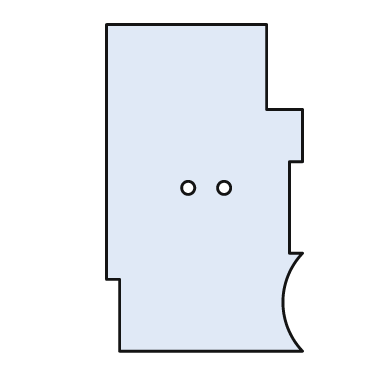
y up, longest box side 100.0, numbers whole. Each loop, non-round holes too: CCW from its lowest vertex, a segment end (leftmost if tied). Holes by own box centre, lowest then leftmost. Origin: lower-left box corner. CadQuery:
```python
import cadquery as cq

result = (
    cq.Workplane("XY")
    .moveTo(4.0, 0.0)
    .lineTo(60.0, 0.0)
    .threePointArc((54.0, 15.0), (60.0, 30.0))
    .lineTo(56.0, 30.0)
    .lineTo(56.0, 58.0)
    .lineTo(60.0, 58.0)
    .lineTo(60.0, 74.0)
    .lineTo(49.0, 74.0)
    .lineTo(49.0, 100.0)
    .lineTo(0.0, 100.0)
    .lineTo(0.0, 22.0)
    .lineTo(4.0, 22.0)
    .close()
    .moveTo(25.0, 50.0)
    .circle(2.0)
    .moveTo(36.0, 50.0)
    .circle(2.0)
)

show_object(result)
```